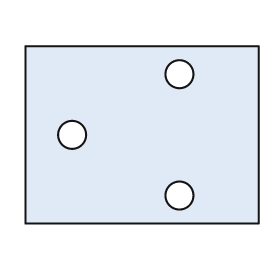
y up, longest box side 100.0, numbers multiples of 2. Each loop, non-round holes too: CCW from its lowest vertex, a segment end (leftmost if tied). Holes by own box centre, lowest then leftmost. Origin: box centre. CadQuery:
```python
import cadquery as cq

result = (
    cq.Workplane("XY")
    .moveTo(-50.0, -38.0)
    .lineTo(50.0, -38.0)
    .lineTo(50.0, 38.0)
    .lineTo(-50.0, 38.0)
    .close()
    .moveTo(16.0, -26.0)
    .circle(6.0)
    .moveTo(-30.0, 0.0)
    .circle(6.0)
    .moveTo(16.0, 26.0)
    .circle(6.0)
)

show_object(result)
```